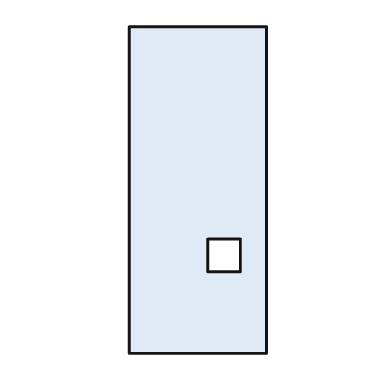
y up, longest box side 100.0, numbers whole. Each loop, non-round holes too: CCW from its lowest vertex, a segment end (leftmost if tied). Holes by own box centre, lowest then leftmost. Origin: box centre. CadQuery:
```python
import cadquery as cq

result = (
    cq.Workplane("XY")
    .moveTo(-21.0, -50.0)
    .lineTo(21.0, -50.0)
    .lineTo(21.0, 50.0)
    .lineTo(-21.0, 50.0)
    .close()
    .moveTo(3.0, -25.0)
    .lineTo(13.0, -25.0)
    .lineTo(13.0, -15.0)
    .lineTo(3.0, -15.0)
    .close()
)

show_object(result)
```